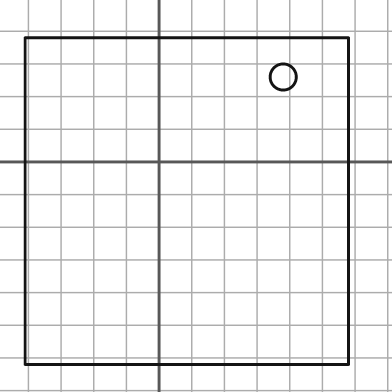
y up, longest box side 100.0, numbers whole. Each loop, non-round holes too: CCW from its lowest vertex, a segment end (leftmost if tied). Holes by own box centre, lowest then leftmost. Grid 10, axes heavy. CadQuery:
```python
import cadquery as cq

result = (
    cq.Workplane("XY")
    .moveTo(-41.0, -62.0)
    .lineTo(58.0, -62.0)
    .lineTo(58.0, 38.0)
    .lineTo(-41.0, 38.0)
    .close()
    .moveTo(38.0, 26.0)
    .circle(4.0)
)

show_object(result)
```